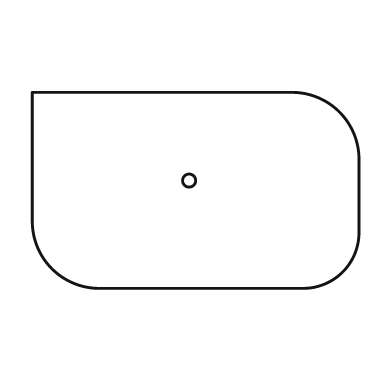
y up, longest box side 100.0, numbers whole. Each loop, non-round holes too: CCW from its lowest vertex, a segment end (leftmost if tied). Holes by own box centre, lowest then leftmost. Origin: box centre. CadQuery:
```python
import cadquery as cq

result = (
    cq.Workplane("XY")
    .moveTo(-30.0, -30.0)
    .lineTo(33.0, -30.0)
    .threePointArc((45.0, -25.0), (50.0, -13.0))
    .lineTo(50.0, 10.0)
    .threePointArc((44.0, 24.0), (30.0, 30.0))
    .lineTo(-50.0, 30.0)
    .lineTo(-50.0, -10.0)
    .threePointArc((-44.0, -24.0), (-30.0, -30.0))
    .close()
    .moveTo(-2.0, 3.0)
    .circle(2.0)
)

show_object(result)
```